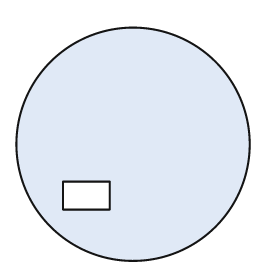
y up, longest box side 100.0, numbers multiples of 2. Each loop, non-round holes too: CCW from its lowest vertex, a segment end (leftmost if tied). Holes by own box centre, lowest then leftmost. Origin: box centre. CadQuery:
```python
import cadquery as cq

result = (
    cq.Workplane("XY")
    .moveTo(0.0, 0.0)
    .circle(50.0)
    .moveTo(-30.0, -28.0)
    .lineTo(-10.0, -28.0)
    .lineTo(-10.0, -16.0)
    .lineTo(-30.0, -16.0)
    .close()
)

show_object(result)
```